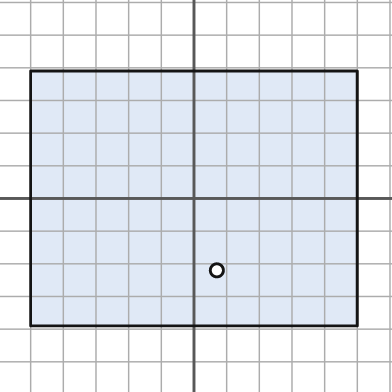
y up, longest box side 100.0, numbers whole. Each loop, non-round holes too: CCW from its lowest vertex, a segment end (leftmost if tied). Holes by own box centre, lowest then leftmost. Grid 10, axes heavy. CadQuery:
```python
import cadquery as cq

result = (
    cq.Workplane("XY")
    .moveTo(-50.0, -39.0)
    .lineTo(50.0, -39.0)
    .lineTo(50.0, 39.0)
    .lineTo(-50.0, 39.0)
    .close()
    .moveTo(7.0, -22.0)
    .circle(2.0)
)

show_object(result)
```